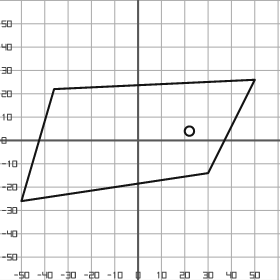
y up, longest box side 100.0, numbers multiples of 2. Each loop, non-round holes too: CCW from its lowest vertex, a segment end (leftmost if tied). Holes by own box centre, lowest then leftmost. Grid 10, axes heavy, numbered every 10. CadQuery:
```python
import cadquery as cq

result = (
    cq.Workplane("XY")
    .moveTo(-50.0, -26.0)
    .lineTo(30.0, -14.0)
    .lineTo(50.0, 26.0)
    .lineTo(-36.0, 22.0)
    .close()
    .moveTo(22.0, 4.0)
    .circle(2.0)
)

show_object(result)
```